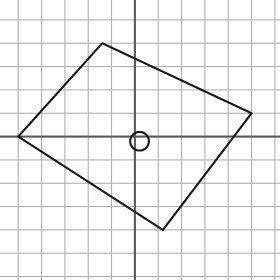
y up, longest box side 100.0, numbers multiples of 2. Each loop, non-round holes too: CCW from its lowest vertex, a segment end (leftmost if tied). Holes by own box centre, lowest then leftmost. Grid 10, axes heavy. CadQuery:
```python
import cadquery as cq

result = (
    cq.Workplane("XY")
    .moveTo(12.0, -40.0)
    .lineTo(50.0, 10.0)
    .lineTo(-14.0, 40.0)
    .lineTo(-50.0, 0.0)
    .close()
    .moveTo(2.0, -2.0)
    .circle(4.0)
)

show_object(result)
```